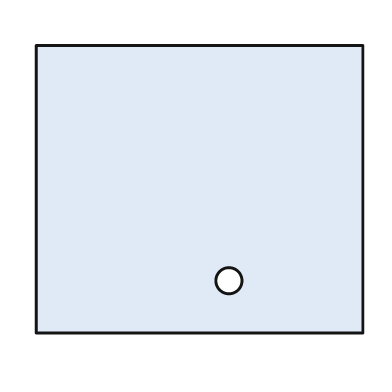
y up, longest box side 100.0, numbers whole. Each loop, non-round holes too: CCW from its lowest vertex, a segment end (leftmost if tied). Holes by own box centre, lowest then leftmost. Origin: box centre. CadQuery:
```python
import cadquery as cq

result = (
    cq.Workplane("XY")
    .moveTo(-50.0, -44.0)
    .lineTo(50.0, -44.0)
    .lineTo(50.0, 44.0)
    .lineTo(-50.0, 44.0)
    .close()
    .moveTo(9.0, -28.0)
    .circle(4.0)
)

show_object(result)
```